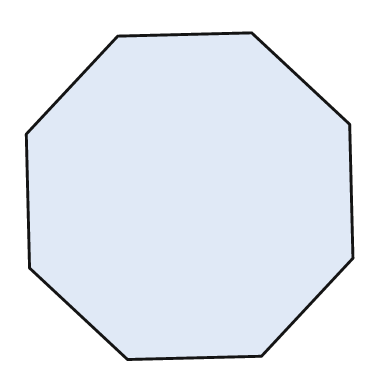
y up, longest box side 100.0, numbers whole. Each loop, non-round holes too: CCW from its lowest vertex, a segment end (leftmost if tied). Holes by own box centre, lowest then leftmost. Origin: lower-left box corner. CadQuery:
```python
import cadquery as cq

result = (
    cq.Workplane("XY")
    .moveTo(31.0, 0.0)
    .lineTo(72.0, 1.0)
    .lineTo(100.0, 31.0)
    .lineTo(99.0, 72.0)
    .lineTo(69.0, 100.0)
    .lineTo(28.0, 99.0)
    .lineTo(0.0, 69.0)
    .lineTo(1.0, 28.0)
    .close()
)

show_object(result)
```